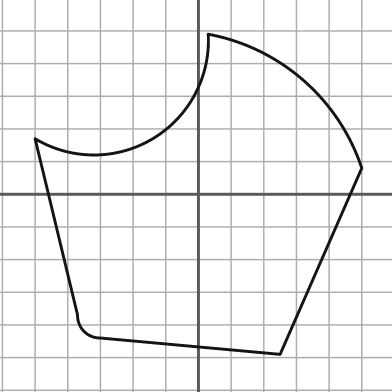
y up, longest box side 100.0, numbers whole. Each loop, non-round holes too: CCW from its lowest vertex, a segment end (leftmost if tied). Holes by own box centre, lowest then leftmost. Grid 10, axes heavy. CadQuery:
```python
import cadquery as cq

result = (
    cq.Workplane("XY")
    .moveTo(25.0, -49.0)
    .lineTo(50.0, 8.0)
    .threePointArc((32.0, 35.0), (3.0, 49.0))
    .threePointArc((-14.0, 17.0), (-50.0, 17.0))
    .lineTo(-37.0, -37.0)
    .threePointArc((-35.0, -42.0), (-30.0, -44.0))
    .close()
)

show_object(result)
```